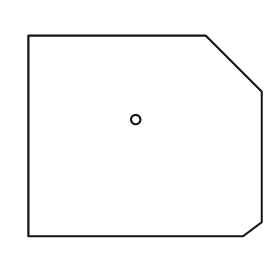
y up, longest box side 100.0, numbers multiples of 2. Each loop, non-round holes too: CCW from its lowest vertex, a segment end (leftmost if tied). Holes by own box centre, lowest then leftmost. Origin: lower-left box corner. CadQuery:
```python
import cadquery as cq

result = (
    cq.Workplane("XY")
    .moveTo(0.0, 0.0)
    .lineTo(92.0, 0.0)
    .lineTo(100.0, 6.0)
    .lineTo(100.0, 62.0)
    .lineTo(76.0, 86.0)
    .lineTo(0.0, 86.0)
    .close()
    .moveTo(46.0, 50.0)
    .circle(2.0)
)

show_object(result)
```